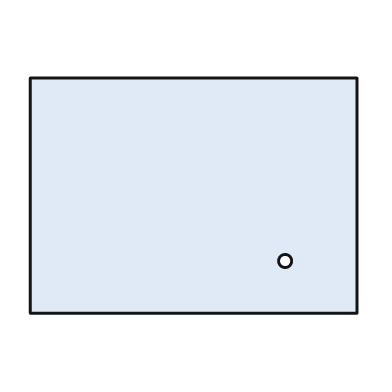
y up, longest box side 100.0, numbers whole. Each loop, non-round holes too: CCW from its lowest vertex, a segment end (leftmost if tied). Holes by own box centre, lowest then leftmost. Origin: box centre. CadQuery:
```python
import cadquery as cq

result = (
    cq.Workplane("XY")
    .moveTo(-50.0, -36.0)
    .lineTo(50.0, -36.0)
    .lineTo(50.0, 36.0)
    .lineTo(-50.0, 36.0)
    .close()
    .moveTo(28.0, -20.0)
    .circle(2.0)
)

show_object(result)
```